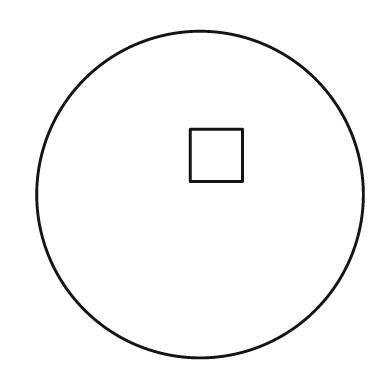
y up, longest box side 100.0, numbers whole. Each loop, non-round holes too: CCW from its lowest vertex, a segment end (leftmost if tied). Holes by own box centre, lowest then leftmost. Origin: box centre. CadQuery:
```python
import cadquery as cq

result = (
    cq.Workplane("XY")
    .moveTo(0.0, 0.0)
    .circle(50.0)
    .moveTo(-3.0, 4.0)
    .lineTo(13.0, 4.0)
    .lineTo(13.0, 20.0)
    .lineTo(-3.0, 20.0)
    .close()
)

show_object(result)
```